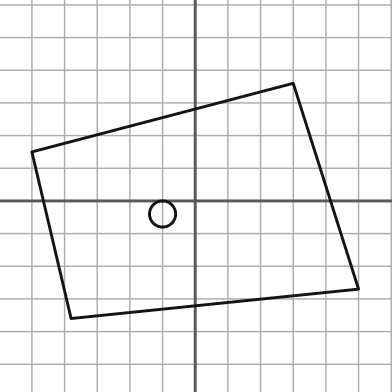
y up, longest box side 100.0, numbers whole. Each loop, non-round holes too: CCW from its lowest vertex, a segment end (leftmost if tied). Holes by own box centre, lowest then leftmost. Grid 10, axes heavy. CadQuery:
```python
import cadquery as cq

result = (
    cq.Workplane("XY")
    .moveTo(-38.0, -36.0)
    .lineTo(50.0, -27.0)
    .lineTo(30.0, 36.0)
    .lineTo(-50.0, 15.0)
    .close()
    .moveTo(-10.0, -4.0)
    .circle(4.0)
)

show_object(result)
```